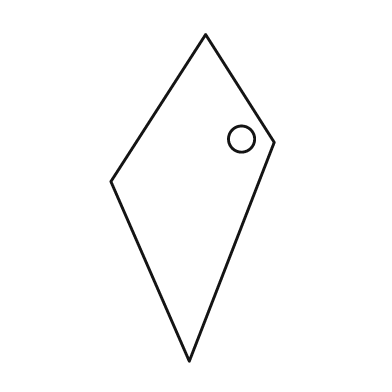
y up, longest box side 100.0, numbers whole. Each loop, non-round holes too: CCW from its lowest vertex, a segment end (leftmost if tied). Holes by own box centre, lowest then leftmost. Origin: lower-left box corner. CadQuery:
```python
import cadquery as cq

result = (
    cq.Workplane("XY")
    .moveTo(24.0, 0.0)
    .lineTo(50.0, 67.0)
    .lineTo(29.0, 100.0)
    .lineTo(0.0, 55.0)
    .close()
    .moveTo(40.0, 68.0)
    .circle(4.0)
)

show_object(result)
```